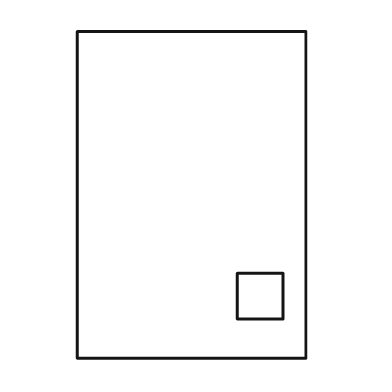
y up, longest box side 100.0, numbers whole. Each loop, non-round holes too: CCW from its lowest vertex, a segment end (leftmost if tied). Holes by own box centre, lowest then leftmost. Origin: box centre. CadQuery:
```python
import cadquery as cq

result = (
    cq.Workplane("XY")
    .moveTo(-35.0, -50.0)
    .lineTo(35.0, -50.0)
    .lineTo(35.0, 50.0)
    .lineTo(-35.0, 50.0)
    .close()
    .moveTo(14.0, -38.0)
    .lineTo(28.0, -38.0)
    .lineTo(28.0, -24.0)
    .lineTo(14.0, -24.0)
    .close()
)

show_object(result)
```